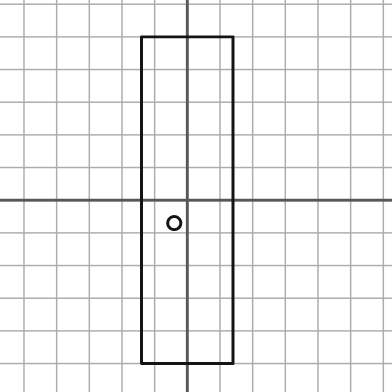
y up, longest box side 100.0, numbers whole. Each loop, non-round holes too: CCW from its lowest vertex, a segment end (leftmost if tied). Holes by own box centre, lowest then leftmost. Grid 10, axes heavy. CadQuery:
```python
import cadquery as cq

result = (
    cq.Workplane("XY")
    .moveTo(-14.0, -50.0)
    .lineTo(14.0, -50.0)
    .lineTo(14.0, 50.0)
    .lineTo(-14.0, 50.0)
    .close()
    .moveTo(-4.0, -7.0)
    .circle(2.0)
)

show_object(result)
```